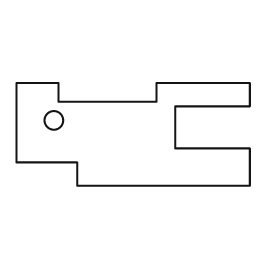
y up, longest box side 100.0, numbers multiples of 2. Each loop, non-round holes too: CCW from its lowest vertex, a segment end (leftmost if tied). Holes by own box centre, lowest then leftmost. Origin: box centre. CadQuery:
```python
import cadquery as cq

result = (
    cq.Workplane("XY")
    .moveTo(-24.0, -22.0)
    .lineTo(50.0, -22.0)
    .lineTo(50.0, -6.0)
    .lineTo(18.0, -6.0)
    .lineTo(18.0, 12.0)
    .lineTo(50.0, 12.0)
    .lineTo(50.0, 22.0)
    .lineTo(10.0, 22.0)
    .lineTo(10.0, 14.0)
    .lineTo(-32.0, 14.0)
    .lineTo(-32.0, 22.0)
    .lineTo(-50.0, 22.0)
    .lineTo(-50.0, -12.0)
    .lineTo(-24.0, -12.0)
    .close()
    .moveTo(-34.0, 6.0)
    .circle(4.0)
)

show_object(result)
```